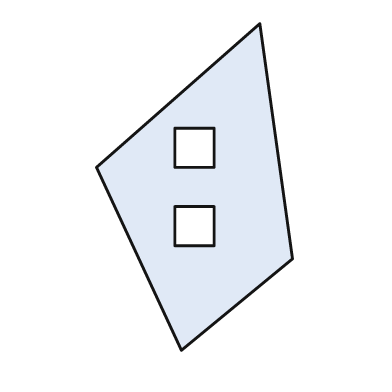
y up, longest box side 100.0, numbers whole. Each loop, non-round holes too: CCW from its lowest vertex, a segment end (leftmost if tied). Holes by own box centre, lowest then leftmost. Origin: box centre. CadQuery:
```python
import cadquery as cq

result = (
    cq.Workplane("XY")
    .moveTo(-4.0, -50.0)
    .lineTo(30.0, -22.0)
    .lineTo(20.0, 50.0)
    .lineTo(-30.0, 6.0)
    .close()
    .moveTo(-6.0, -18.0)
    .lineTo(6.0, -18.0)
    .lineTo(6.0, -6.0)
    .lineTo(-6.0, -6.0)
    .close()
    .moveTo(-6.0, 6.0)
    .lineTo(6.0, 6.0)
    .lineTo(6.0, 18.0)
    .lineTo(-6.0, 18.0)
    .close()
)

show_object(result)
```